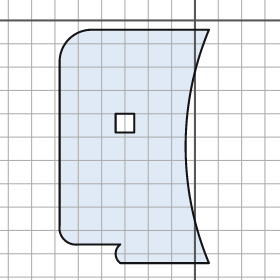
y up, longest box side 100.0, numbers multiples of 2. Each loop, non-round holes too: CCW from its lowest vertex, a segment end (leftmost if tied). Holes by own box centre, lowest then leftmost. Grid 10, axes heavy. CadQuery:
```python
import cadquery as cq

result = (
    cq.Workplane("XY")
    .moveTo(-32.0, -104.0)
    .lineTo(6.0, -104.0)
    .threePointArc((-4.0, -54.0), (6.0, -4.0))
    .lineTo(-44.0, -4.0)
    .threePointArc((-54.0, -8.0), (-58.0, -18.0))
    .lineTo(-58.0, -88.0)
    .threePointArc((-56.0, -94.0), (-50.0, -96.0))
    .lineTo(-32.0, -96.0)
    .threePointArc((-34.0, -100.0), (-32.0, -104.0))
    .close()
    .moveTo(-34.0, -48.0)
    .lineTo(-26.0, -48.0)
    .lineTo(-26.0, -40.0)
    .lineTo(-34.0, -40.0)
    .close()
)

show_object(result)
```